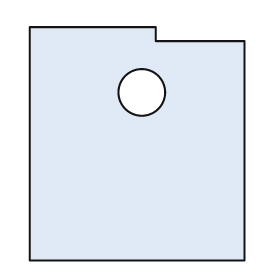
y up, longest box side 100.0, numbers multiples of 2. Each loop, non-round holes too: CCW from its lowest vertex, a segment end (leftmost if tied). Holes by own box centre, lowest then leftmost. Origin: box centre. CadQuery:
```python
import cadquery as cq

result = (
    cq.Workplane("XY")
    .moveTo(-46.0, -50.0)
    .lineTo(46.0, -50.0)
    .lineTo(46.0, 44.0)
    .lineTo(8.0, 44.0)
    .lineTo(8.0, 50.0)
    .lineTo(-46.0, 50.0)
    .close()
    .moveTo(2.0, 22.0)
    .circle(10.0)
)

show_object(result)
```